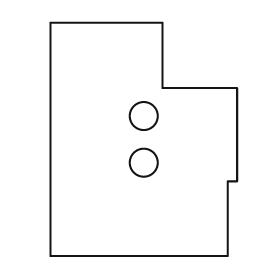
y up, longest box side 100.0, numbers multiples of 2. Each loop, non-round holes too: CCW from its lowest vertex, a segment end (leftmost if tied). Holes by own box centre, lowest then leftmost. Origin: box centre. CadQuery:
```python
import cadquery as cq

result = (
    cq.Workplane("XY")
    .moveTo(-40.0, -50.0)
    .lineTo(36.0, -50.0)
    .lineTo(36.0, -18.0)
    .lineTo(40.0, -18.0)
    .lineTo(40.0, 22.0)
    .lineTo(8.0, 22.0)
    .lineTo(8.0, 50.0)
    .lineTo(-40.0, 50.0)
    .close()
    .moveTo(0.0, -10.0)
    .circle(6.0)
    .moveTo(0.0, 10.0)
    .circle(6.0)
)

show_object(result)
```